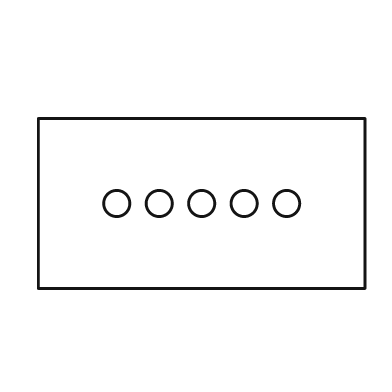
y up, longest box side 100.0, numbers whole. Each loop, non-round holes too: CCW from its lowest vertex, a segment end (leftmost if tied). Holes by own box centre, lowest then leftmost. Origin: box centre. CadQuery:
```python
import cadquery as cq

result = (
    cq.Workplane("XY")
    .moveTo(-50.0, -26.0)
    .lineTo(50.0, -26.0)
    .lineTo(50.0, 26.0)
    .lineTo(-50.0, 26.0)
    .close()
    .moveTo(-26.0, 0.0)
    .circle(4.0)
    .moveTo(-13.0, 0.0)
    .circle(4.0)
    .moveTo(0.0, 0.0)
    .circle(4.0)
    .moveTo(13.0, 0.0)
    .circle(4.0)
    .moveTo(26.0, 0.0)
    .circle(4.0)
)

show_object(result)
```